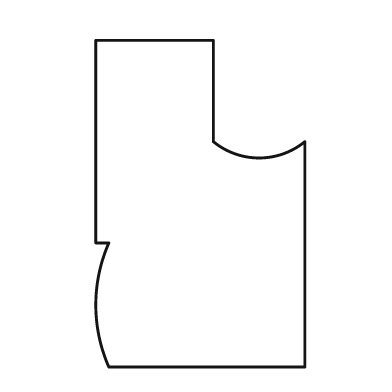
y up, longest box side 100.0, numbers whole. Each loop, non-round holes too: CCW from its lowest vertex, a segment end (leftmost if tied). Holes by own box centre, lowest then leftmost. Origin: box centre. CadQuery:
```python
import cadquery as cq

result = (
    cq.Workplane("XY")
    .moveTo(-28.0, -50.0)
    .lineTo(32.0, -50.0)
    .lineTo(32.0, 19.0)
    .threePointArc((18.0, 14.0), (4.0, 19.0))
    .lineTo(4.0, 50.0)
    .lineTo(-32.0, 50.0)
    .lineTo(-32.0, -12.0)
    .lineTo(-28.0, -12.0)
    .threePointArc((-32.0, -31.0), (-28.0, -50.0))
    .close()
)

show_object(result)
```